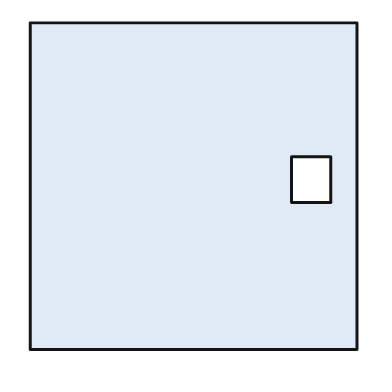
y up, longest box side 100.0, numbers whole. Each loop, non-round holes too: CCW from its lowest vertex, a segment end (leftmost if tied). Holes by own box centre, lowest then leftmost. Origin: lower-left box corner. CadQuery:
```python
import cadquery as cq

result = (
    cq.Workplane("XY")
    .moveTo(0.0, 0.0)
    .lineTo(100.0, 0.0)
    .lineTo(100.0, 100.0)
    .lineTo(0.0, 100.0)
    .close()
    .moveTo(80.0, 45.0)
    .lineTo(92.0, 45.0)
    .lineTo(92.0, 59.0)
    .lineTo(80.0, 59.0)
    .close()
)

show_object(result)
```